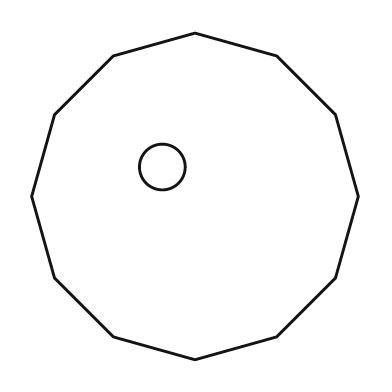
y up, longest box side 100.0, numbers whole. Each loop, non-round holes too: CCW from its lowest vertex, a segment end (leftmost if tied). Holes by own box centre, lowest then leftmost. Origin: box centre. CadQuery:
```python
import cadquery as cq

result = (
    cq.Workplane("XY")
    .moveTo(0.0, -50.0)
    .lineTo(25.0, -43.0)
    .lineTo(43.0, -25.0)
    .lineTo(50.0, 0.0)
    .lineTo(43.0, 25.0)
    .lineTo(25.0, 43.0)
    .lineTo(0.0, 50.0)
    .lineTo(-25.0, 43.0)
    .lineTo(-43.0, 25.0)
    .lineTo(-50.0, 0.0)
    .lineTo(-43.0, -25.0)
    .lineTo(-25.0, -43.0)
    .close()
    .moveTo(-10.0, 9.0)
    .circle(7.0)
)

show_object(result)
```